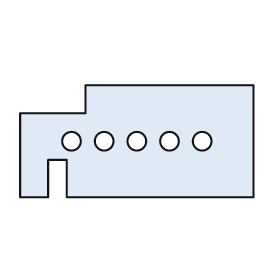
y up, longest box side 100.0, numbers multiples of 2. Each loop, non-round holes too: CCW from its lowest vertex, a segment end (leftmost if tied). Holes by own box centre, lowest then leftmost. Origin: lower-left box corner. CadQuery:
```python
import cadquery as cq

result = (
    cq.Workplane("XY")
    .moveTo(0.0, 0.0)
    .lineTo(12.0, 0.0)
    .lineTo(12.0, 16.0)
    .lineTo(20.0, 16.0)
    .lineTo(20.0, 0.0)
    .lineTo(100.0, 0.0)
    .lineTo(100.0, 48.0)
    .lineTo(28.0, 48.0)
    .lineTo(28.0, 36.0)
    .lineTo(0.0, 36.0)
    .close()
    .moveTo(22.0, 24.0)
    .circle(4.0)
    .moveTo(36.0, 24.0)
    .circle(4.0)
    .moveTo(50.0, 24.0)
    .circle(4.0)
    .moveTo(64.0, 24.0)
    .circle(4.0)
    .moveTo(78.0, 24.0)
    .circle(4.0)
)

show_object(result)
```